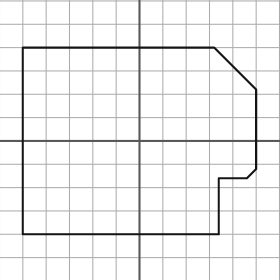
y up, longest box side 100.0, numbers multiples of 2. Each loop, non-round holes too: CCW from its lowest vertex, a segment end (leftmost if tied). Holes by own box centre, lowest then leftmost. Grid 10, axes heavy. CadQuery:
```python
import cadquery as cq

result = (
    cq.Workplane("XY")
    .moveTo(-50.0, -40.0)
    .lineTo(34.0, -40.0)
    .lineTo(34.0, -16.0)
    .lineTo(46.0, -16.0)
    .lineTo(50.0, -12.0)
    .lineTo(50.0, 22.0)
    .lineTo(32.0, 40.0)
    .lineTo(-50.0, 40.0)
    .close()
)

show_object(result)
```